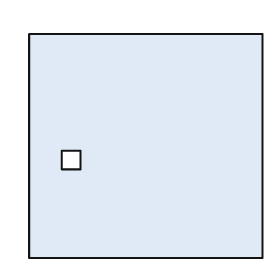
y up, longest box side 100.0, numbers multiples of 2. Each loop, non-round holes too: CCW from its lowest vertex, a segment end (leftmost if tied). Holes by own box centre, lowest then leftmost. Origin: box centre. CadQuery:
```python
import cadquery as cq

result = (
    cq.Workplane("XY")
    .moveTo(-50.0, -48.0)
    .lineTo(50.0, -48.0)
    .lineTo(50.0, 48.0)
    .lineTo(-50.0, 48.0)
    .close()
    .moveTo(-36.0, -10.0)
    .lineTo(-28.0, -10.0)
    .lineTo(-28.0, -2.0)
    .lineTo(-36.0, -2.0)
    .close()
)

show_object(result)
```